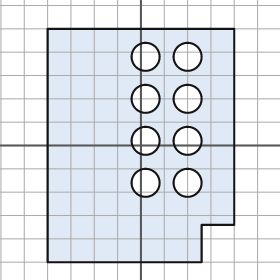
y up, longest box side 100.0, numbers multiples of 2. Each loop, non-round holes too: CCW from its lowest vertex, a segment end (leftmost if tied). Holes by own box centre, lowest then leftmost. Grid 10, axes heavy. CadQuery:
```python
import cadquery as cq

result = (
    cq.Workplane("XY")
    .moveTo(-40.0, -50.0)
    .lineTo(26.0, -50.0)
    .lineTo(26.0, -34.0)
    .lineTo(40.0, -34.0)
    .lineTo(40.0, 50.0)
    .lineTo(-40.0, 50.0)
    .close()
    .moveTo(2.0, -16.0)
    .circle(6.0)
    .moveTo(20.0, -16.0)
    .circle(6.0)
    .moveTo(2.0, 2.0)
    .circle(6.0)
    .moveTo(20.0, 2.0)
    .circle(6.0)
    .moveTo(2.0, 20.0)
    .circle(6.0)
    .moveTo(20.0, 20.0)
    .circle(6.0)
    .moveTo(2.0, 38.0)
    .circle(6.0)
    .moveTo(20.0, 38.0)
    .circle(6.0)
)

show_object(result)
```